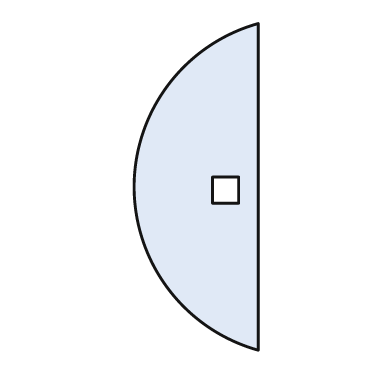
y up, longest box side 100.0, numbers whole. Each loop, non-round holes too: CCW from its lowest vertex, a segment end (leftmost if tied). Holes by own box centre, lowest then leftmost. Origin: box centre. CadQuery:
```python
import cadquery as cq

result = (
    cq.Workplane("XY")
    .moveTo(19.0, -50.0)
    .lineTo(19.0, 50.0)
    .threePointArc((-19.0, 0.0), (19.0, -50.0))
    .close()
    .moveTo(5.0, -5.0)
    .lineTo(13.0, -5.0)
    .lineTo(13.0, 3.0)
    .lineTo(5.0, 3.0)
    .close()
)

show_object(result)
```